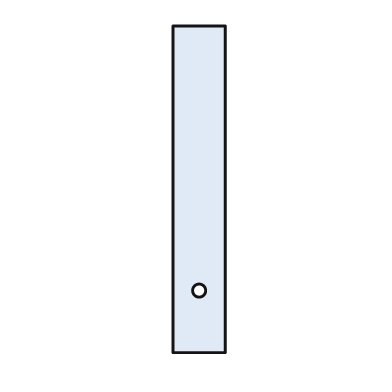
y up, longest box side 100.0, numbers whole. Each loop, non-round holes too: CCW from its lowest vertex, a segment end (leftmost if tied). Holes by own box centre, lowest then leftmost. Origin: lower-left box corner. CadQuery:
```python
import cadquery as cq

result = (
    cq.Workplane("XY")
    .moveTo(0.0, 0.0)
    .lineTo(16.0, 0.0)
    .lineTo(16.0, 100.0)
    .lineTo(0.0, 100.0)
    .close()
    .moveTo(8.0, 19.0)
    .circle(2.0)
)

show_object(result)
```